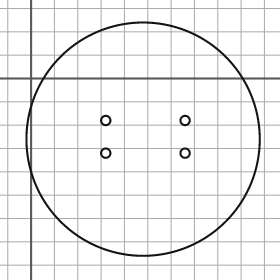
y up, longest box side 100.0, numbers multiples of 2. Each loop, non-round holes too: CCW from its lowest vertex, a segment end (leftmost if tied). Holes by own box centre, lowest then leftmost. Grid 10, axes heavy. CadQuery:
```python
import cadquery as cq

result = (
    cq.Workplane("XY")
    .moveTo(48.0, -26.0)
    .circle(50.0)
    .moveTo(32.0, -32.0)
    .circle(2.0)
    .moveTo(66.0, -32.0)
    .circle(2.0)
    .moveTo(32.0, -18.0)
    .circle(2.0)
    .moveTo(66.0, -18.0)
    .circle(2.0)
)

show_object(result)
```